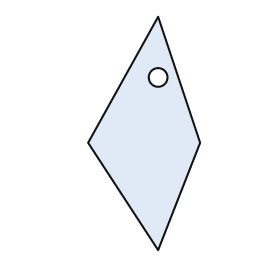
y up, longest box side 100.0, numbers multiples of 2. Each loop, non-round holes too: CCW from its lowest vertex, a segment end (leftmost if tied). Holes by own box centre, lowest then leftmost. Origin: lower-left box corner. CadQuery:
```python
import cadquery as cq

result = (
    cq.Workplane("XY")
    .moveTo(30.0, 0.0)
    .lineTo(48.0, 46.0)
    .lineTo(30.0, 100.0)
    .lineTo(0.0, 46.0)
    .close()
    .moveTo(30.0, 74.0)
    .circle(4.0)
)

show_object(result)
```